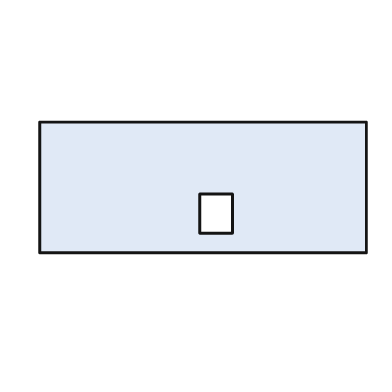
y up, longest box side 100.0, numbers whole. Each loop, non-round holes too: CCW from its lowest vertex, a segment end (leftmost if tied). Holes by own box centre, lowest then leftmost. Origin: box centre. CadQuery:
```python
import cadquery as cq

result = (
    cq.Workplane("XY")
    .moveTo(-50.0, -20.0)
    .lineTo(50.0, -20.0)
    .lineTo(50.0, 20.0)
    .lineTo(-50.0, 20.0)
    .close()
    .moveTo(-1.0, -14.0)
    .lineTo(9.0, -14.0)
    .lineTo(9.0, -2.0)
    .lineTo(-1.0, -2.0)
    .close()
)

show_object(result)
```